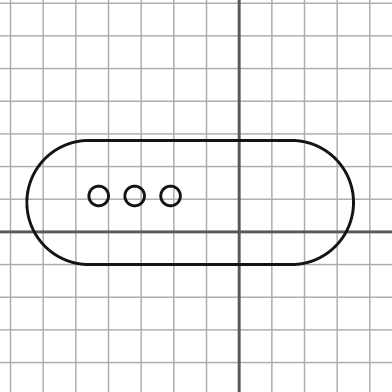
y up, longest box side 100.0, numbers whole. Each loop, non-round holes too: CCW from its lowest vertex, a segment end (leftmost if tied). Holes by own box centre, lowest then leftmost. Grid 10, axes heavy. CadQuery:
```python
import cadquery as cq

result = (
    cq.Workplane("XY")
    .moveTo(-46.0, -10.0)
    .lineTo(16.0, -10.0)
    .threePointArc((35.0, 9.0), (16.0, 28.0))
    .lineTo(-46.0, 28.0)
    .threePointArc((-65.0, 9.0), (-46.0, -10.0))
    .close()
    .moveTo(-43.0, 11.0)
    .circle(3.0)
    .moveTo(-32.0, 11.0)
    .circle(3.0)
    .moveTo(-21.0, 11.0)
    .circle(3.0)
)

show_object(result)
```